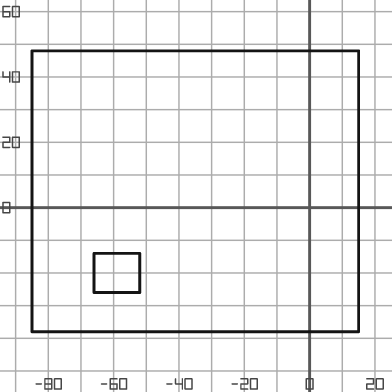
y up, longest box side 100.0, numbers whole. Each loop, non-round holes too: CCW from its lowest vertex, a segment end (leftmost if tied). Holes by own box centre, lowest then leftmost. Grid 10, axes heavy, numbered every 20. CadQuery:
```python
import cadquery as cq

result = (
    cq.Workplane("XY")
    .moveTo(-85.0, -38.0)
    .lineTo(15.0, -38.0)
    .lineTo(15.0, 48.0)
    .lineTo(-85.0, 48.0)
    .close()
    .moveTo(-66.0, -26.0)
    .lineTo(-52.0, -26.0)
    .lineTo(-52.0, -14.0)
    .lineTo(-66.0, -14.0)
    .close()
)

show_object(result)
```